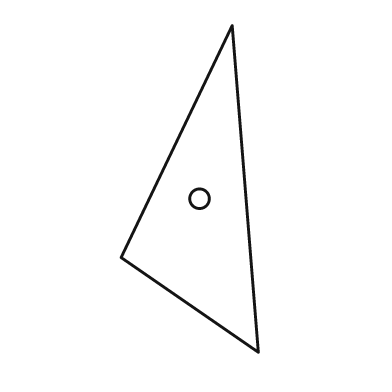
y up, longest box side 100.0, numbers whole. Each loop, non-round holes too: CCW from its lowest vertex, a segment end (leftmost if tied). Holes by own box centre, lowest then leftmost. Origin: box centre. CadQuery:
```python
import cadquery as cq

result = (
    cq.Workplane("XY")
    .moveTo(21.0, -50.0)
    .lineTo(13.0, 50.0)
    .lineTo(-21.0, -21.0)
    .close()
    .moveTo(3.0, -3.0)
    .circle(3.0)
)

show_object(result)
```